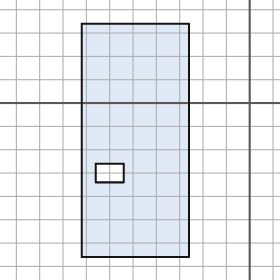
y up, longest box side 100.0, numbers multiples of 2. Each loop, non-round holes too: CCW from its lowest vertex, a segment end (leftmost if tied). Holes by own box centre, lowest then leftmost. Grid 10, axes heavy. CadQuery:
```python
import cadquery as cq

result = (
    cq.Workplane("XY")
    .moveTo(-72.0, -66.0)
    .lineTo(-26.0, -66.0)
    .lineTo(-26.0, 34.0)
    .lineTo(-72.0, 34.0)
    .close()
    .moveTo(-66.0, -34.0)
    .lineTo(-54.0, -34.0)
    .lineTo(-54.0, -26.0)
    .lineTo(-66.0, -26.0)
    .close()
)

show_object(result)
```